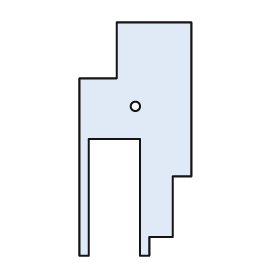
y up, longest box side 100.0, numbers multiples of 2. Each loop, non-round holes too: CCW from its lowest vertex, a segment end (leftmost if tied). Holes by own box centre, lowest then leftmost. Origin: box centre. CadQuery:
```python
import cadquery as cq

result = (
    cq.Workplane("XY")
    .moveTo(-24.0, -50.0)
    .lineTo(-20.0, -50.0)
    .lineTo(-20.0, 0.0)
    .lineTo(2.0, 0.0)
    .lineTo(2.0, -50.0)
    .lineTo(6.0, -50.0)
    .lineTo(6.0, -42.0)
    .lineTo(16.0, -42.0)
    .lineTo(16.0, -16.0)
    .lineTo(24.0, -16.0)
    .lineTo(24.0, 50.0)
    .lineTo(-8.0, 50.0)
    .lineTo(-8.0, 26.0)
    .lineTo(-24.0, 26.0)
    .close()
    .moveTo(0.0, 14.0)
    .circle(2.0)
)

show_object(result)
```